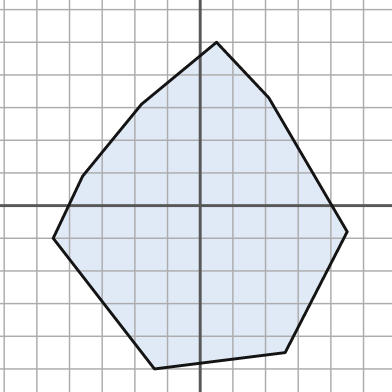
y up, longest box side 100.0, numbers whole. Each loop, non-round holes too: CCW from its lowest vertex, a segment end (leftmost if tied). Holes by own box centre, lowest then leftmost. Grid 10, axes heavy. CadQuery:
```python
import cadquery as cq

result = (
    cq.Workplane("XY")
    .moveTo(-14.0, -50.0)
    .lineTo(26.0, -45.0)
    .lineTo(45.0, -8.0)
    .lineTo(21.0, 33.0)
    .lineTo(5.0, 50.0)
    .lineTo(-18.0, 31.0)
    .lineTo(-36.0, 9.0)
    .lineTo(-45.0, -10.0)
    .close()
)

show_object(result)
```